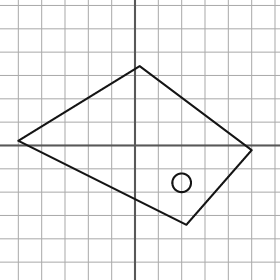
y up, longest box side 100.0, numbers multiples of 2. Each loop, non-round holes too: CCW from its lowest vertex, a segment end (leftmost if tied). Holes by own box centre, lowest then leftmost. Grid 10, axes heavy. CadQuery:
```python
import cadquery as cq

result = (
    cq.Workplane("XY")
    .moveTo(22.0, -34.0)
    .lineTo(50.0, -2.0)
    .lineTo(2.0, 34.0)
    .lineTo(-50.0, 2.0)
    .close()
    .moveTo(20.0, -16.0)
    .circle(4.0)
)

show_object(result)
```